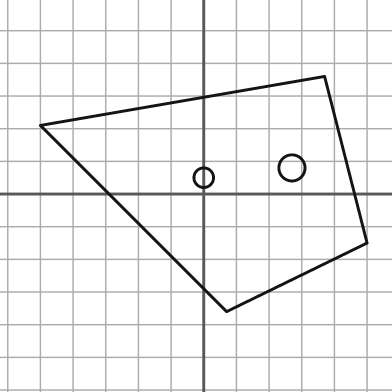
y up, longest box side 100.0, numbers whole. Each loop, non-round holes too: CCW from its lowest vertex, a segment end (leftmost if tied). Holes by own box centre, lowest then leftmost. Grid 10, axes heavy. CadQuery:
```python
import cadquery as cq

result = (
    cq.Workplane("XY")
    .moveTo(7.0, -36.0)
    .lineTo(50.0, -15.0)
    .lineTo(37.0, 36.0)
    .lineTo(-50.0, 21.0)
    .close()
    .moveTo(0.0, 5.0)
    .circle(3.0)
    .moveTo(27.0, 8.0)
    .circle(4.0)
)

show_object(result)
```